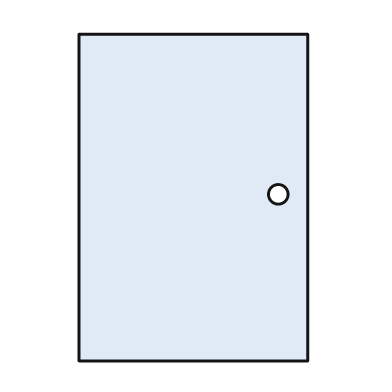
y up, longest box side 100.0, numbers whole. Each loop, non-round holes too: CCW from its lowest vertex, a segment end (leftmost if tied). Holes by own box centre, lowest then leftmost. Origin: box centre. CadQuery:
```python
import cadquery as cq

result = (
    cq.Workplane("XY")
    .moveTo(-35.0, -50.0)
    .lineTo(35.0, -50.0)
    .lineTo(35.0, 50.0)
    .lineTo(-35.0, 50.0)
    .close()
    .moveTo(26.0, 1.0)
    .circle(3.0)
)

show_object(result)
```